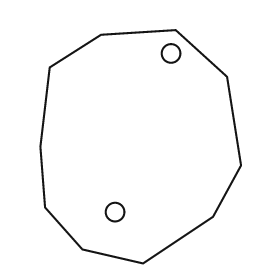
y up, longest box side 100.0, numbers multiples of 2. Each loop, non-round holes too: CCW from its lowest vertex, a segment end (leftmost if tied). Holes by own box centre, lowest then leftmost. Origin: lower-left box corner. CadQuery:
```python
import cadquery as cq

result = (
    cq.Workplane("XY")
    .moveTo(44.0, 0.0)
    .lineTo(74.0, 20.0)
    .lineTo(86.0, 42.0)
    .lineTo(80.0, 80.0)
    .lineTo(58.0, 100.0)
    .lineTo(26.0, 98.0)
    .lineTo(4.0, 84.0)
    .lineTo(0.0, 50.0)
    .lineTo(2.0, 24.0)
    .lineTo(18.0, 6.0)
    .close()
    .moveTo(32.0, 22.0)
    .circle(4.0)
    .moveTo(56.0, 90.0)
    .circle(4.0)
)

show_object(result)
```